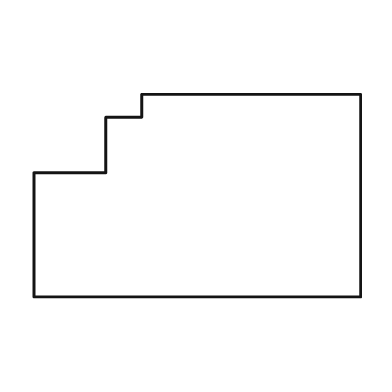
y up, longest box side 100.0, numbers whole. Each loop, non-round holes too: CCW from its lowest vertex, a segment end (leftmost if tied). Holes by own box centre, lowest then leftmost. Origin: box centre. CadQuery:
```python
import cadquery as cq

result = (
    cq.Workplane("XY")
    .moveTo(-50.0, -31.0)
    .lineTo(50.0, -31.0)
    .lineTo(50.0, 31.0)
    .lineTo(-17.0, 31.0)
    .lineTo(-17.0, 24.0)
    .lineTo(-28.0, 24.0)
    .lineTo(-28.0, 7.0)
    .lineTo(-50.0, 7.0)
    .close()
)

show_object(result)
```